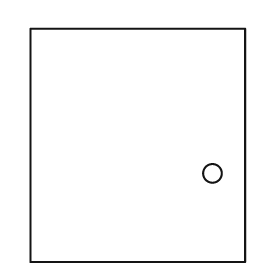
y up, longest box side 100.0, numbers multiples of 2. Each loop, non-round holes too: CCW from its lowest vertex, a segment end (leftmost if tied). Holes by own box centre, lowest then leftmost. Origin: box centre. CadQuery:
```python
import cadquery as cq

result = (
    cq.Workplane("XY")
    .moveTo(-46.0, -50.0)
    .lineTo(46.0, -50.0)
    .lineTo(46.0, 50.0)
    .lineTo(-46.0, 50.0)
    .close()
    .moveTo(32.0, -12.0)
    .circle(4.0)
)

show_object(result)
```